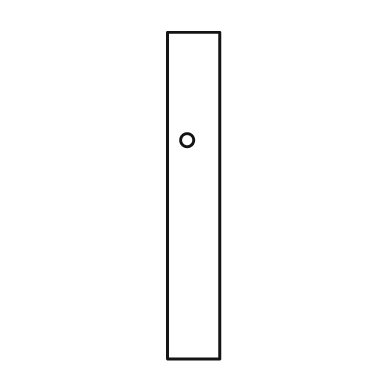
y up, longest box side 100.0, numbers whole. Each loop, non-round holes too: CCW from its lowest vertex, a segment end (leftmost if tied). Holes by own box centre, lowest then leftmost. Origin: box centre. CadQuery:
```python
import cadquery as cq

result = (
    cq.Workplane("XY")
    .moveTo(-8.0, -50.0)
    .lineTo(8.0, -50.0)
    .lineTo(8.0, 50.0)
    .lineTo(-8.0, 50.0)
    .close()
    .moveTo(-2.0, 17.0)
    .circle(2.0)
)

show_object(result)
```